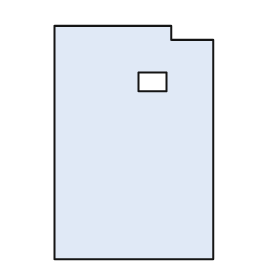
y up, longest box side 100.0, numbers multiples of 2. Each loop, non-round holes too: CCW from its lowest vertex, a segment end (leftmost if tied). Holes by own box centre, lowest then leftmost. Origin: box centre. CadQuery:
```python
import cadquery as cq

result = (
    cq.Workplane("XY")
    .moveTo(-34.0, -50.0)
    .lineTo(34.0, -50.0)
    .lineTo(34.0, 44.0)
    .lineTo(16.0, 44.0)
    .lineTo(16.0, 50.0)
    .lineTo(-34.0, 50.0)
    .close()
    .moveTo(2.0, 22.0)
    .lineTo(14.0, 22.0)
    .lineTo(14.0, 30.0)
    .lineTo(2.0, 30.0)
    .close()
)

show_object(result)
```